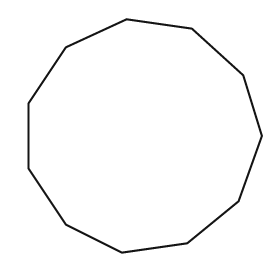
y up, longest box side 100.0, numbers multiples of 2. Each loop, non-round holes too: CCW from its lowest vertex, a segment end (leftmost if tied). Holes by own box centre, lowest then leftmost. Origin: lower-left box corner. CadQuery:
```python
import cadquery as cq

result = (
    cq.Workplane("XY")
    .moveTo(40.0, 0.0)
    .lineTo(68.0, 4.0)
    .lineTo(90.0, 22.0)
    .lineTo(100.0, 50.0)
    .lineTo(92.0, 76.0)
    .lineTo(70.0, 96.0)
    .lineTo(42.0, 100.0)
    .lineTo(16.0, 88.0)
    .lineTo(0.0, 64.0)
    .lineTo(0.0, 36.0)
    .lineTo(16.0, 12.0)
    .close()
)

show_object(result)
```